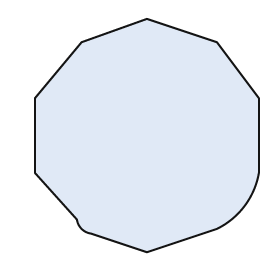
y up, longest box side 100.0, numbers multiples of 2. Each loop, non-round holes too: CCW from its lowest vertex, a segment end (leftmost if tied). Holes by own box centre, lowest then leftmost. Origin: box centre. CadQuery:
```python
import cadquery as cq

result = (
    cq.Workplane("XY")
    .moveTo(0.0, -50.0)
    .lineTo(30.0, -40.0)
    .threePointArc((42.0, -30.0), (48.0, -16.0))
    .lineTo(48.0, 16.0)
    .lineTo(30.0, 40.0)
    .lineTo(0.0, 50.0)
    .lineTo(-28.0, 40.0)
    .lineTo(-48.0, 16.0)
    .lineTo(-48.0, -16.0)
    .lineTo(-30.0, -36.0)
    .threePointArc((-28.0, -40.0), (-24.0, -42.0))
    .close()
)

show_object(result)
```